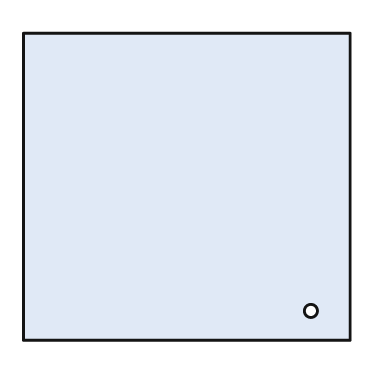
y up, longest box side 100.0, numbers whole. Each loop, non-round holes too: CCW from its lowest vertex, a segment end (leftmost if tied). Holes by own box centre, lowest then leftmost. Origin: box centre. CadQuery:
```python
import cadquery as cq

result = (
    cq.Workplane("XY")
    .moveTo(-50.0, -47.0)
    .lineTo(50.0, -47.0)
    .lineTo(50.0, 47.0)
    .lineTo(-50.0, 47.0)
    .close()
    .moveTo(38.0, -38.0)
    .circle(2.0)
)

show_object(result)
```